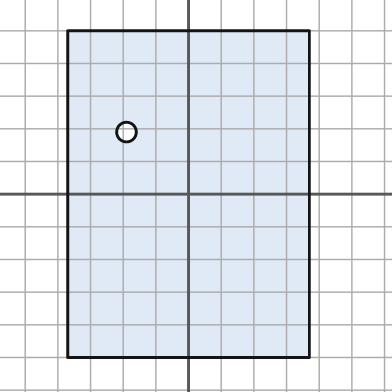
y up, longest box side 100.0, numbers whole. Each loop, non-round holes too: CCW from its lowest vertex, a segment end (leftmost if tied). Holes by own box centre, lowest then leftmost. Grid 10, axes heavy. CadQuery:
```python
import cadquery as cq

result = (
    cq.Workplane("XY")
    .moveTo(-37.0, -50.0)
    .lineTo(37.0, -50.0)
    .lineTo(37.0, 50.0)
    .lineTo(-37.0, 50.0)
    .close()
    .moveTo(-19.0, 19.0)
    .circle(3.0)
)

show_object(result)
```